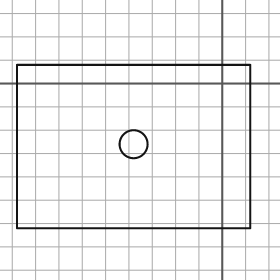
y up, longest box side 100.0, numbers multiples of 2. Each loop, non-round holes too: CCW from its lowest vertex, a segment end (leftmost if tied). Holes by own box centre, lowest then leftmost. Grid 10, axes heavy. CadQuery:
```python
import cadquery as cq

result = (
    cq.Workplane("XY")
    .moveTo(-88.0, -62.0)
    .lineTo(12.0, -62.0)
    .lineTo(12.0, 8.0)
    .lineTo(-88.0, 8.0)
    .close()
    .moveTo(-38.0, -26.0)
    .circle(6.0)
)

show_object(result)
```